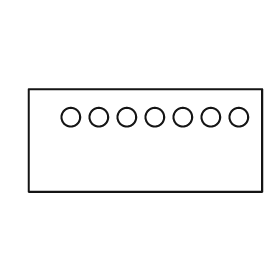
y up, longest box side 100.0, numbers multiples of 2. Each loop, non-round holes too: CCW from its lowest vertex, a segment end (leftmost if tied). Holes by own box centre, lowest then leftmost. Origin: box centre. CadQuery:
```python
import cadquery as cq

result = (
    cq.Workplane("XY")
    .moveTo(-50.0, -22.0)
    .lineTo(50.0, -22.0)
    .lineTo(50.0, 22.0)
    .lineTo(-50.0, 22.0)
    .close()
    .moveTo(-32.0, 10.0)
    .circle(4.0)
    .moveTo(-20.0, 10.0)
    .circle(4.0)
    .moveTo(-8.0, 10.0)
    .circle(4.0)
    .moveTo(4.0, 10.0)
    .circle(4.0)
    .moveTo(16.0, 10.0)
    .circle(4.0)
    .moveTo(28.0, 10.0)
    .circle(4.0)
    .moveTo(40.0, 10.0)
    .circle(4.0)
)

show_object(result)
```